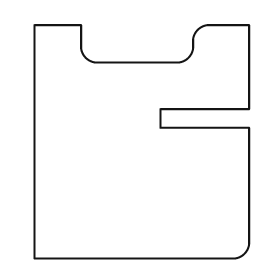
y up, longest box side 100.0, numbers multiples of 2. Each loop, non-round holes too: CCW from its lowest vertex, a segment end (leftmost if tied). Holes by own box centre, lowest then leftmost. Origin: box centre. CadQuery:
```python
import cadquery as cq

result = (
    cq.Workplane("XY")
    .moveTo(-46.0, -50.0)
    .lineTo(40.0, -50.0)
    .threePointArc((44.0, -48.0), (46.0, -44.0))
    .lineTo(46.0, 6.0)
    .lineTo(8.0, 6.0)
    .lineTo(8.0, 14.0)
    .lineTo(46.0, 14.0)
    .lineTo(46.0, 50.0)
    .lineTo(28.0, 50.0)
    .threePointArc((24.0, 48.0), (22.0, 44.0))
    .lineTo(22.0, 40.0)
    .threePointArc((20.0, 36.0), (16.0, 34.0))
    .lineTo(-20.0, 34.0)
    .threePointArc((-24.0, 36.0), (-26.0, 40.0))
    .lineTo(-26.0, 50.0)
    .lineTo(-46.0, 50.0)
    .close()
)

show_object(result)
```